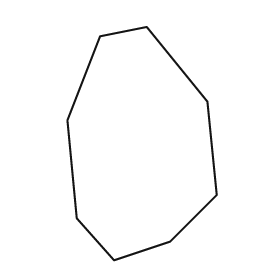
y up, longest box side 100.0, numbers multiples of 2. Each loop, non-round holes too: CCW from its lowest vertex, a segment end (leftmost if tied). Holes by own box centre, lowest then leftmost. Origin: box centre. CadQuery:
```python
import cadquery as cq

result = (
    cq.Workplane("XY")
    .moveTo(-12.0, -50.0)
    .lineTo(12.0, -42.0)
    .lineTo(32.0, -22.0)
    .lineTo(28.0, 18.0)
    .lineTo(2.0, 50.0)
    .lineTo(-18.0, 46.0)
    .lineTo(-32.0, 10.0)
    .lineTo(-28.0, -32.0)
    .close()
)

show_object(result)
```